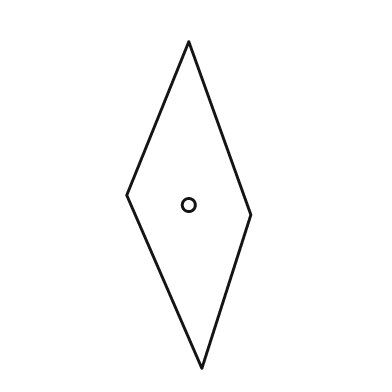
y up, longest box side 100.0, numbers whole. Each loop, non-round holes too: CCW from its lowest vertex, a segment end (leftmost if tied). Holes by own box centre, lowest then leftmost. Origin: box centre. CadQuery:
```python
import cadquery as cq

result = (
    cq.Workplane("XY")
    .moveTo(4.0, -50.0)
    .lineTo(19.0, -3.0)
    .lineTo(0.0, 50.0)
    .lineTo(-19.0, 3.0)
    .close()
    .moveTo(0.0, 0.0)
    .circle(2.0)
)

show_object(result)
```